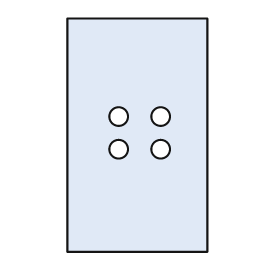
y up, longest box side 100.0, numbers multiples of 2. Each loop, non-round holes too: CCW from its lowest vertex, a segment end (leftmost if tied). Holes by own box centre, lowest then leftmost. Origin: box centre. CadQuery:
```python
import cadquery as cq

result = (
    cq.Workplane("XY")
    .moveTo(-30.0, -50.0)
    .lineTo(30.0, -50.0)
    .lineTo(30.0, 50.0)
    .lineTo(-30.0, 50.0)
    .close()
    .moveTo(-8.0, -6.0)
    .circle(4.0)
    .moveTo(10.0, -6.0)
    .circle(4.0)
    .moveTo(-8.0, 8.0)
    .circle(4.0)
    .moveTo(10.0, 8.0)
    .circle(4.0)
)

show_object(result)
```